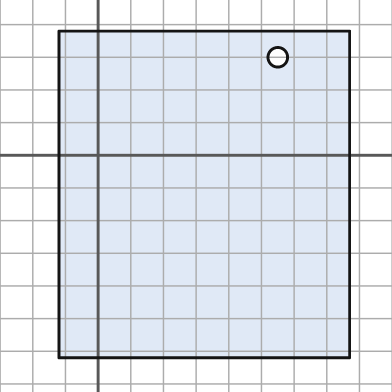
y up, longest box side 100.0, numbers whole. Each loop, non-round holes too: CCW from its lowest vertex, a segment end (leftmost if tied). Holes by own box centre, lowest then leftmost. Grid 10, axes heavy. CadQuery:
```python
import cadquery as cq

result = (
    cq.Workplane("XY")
    .moveTo(-12.0, -62.0)
    .lineTo(77.0, -62.0)
    .lineTo(77.0, 38.0)
    .lineTo(-12.0, 38.0)
    .close()
    .moveTo(55.0, 30.0)
    .circle(3.0)
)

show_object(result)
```